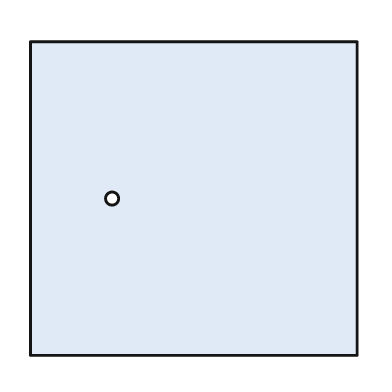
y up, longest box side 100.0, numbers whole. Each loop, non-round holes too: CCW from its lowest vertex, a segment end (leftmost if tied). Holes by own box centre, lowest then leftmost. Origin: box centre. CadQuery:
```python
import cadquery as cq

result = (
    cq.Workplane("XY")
    .moveTo(-50.0, -48.0)
    .lineTo(50.0, -48.0)
    .lineTo(50.0, 48.0)
    .lineTo(-50.0, 48.0)
    .close()
    .moveTo(-25.0, 0.0)
    .circle(2.0)
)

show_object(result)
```